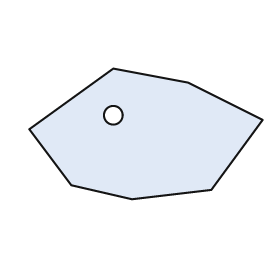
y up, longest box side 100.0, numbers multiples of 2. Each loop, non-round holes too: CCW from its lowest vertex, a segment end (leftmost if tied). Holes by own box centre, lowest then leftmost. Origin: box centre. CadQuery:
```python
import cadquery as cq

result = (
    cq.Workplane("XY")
    .moveTo(-6.0, -28.0)
    .lineTo(28.0, -24.0)
    .lineTo(50.0, 6.0)
    .lineTo(18.0, 22.0)
    .lineTo(-14.0, 28.0)
    .lineTo(-50.0, 2.0)
    .lineTo(-32.0, -22.0)
    .close()
    .moveTo(-14.0, 8.0)
    .circle(4.0)
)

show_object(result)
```